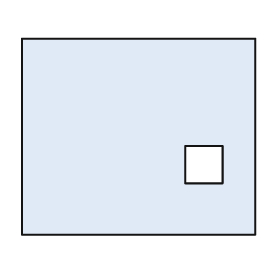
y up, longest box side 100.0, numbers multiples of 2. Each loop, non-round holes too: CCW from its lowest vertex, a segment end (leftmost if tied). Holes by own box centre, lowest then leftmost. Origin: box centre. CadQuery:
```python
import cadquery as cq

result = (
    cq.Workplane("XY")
    .moveTo(-50.0, -42.0)
    .lineTo(50.0, -42.0)
    .lineTo(50.0, 42.0)
    .lineTo(-50.0, 42.0)
    .close()
    .moveTo(20.0, -20.0)
    .lineTo(36.0, -20.0)
    .lineTo(36.0, -4.0)
    .lineTo(20.0, -4.0)
    .close()
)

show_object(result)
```